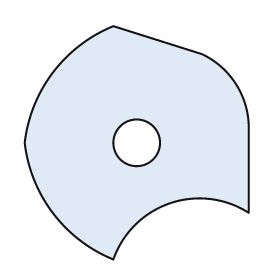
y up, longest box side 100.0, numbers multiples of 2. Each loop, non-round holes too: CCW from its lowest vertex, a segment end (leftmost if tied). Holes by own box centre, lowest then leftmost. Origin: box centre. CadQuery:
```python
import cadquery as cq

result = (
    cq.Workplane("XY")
    .moveTo(-10.0, -50.0)
    .threePointArc((14.0, -26.0), (48.0, -30.0))
    .lineTo(48.0, 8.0)
    .threePointArc((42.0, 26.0), (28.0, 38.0))
    .lineTo(-10.0, 50.0)
    .threePointArc((-36.0, 30.0), (-48.0, 0.0))
    .threePointArc((-36.0, -30.0), (-10.0, -50.0))
    .close()
    .moveTo(0.0, 0.0)
    .circle(10.0)
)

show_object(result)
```